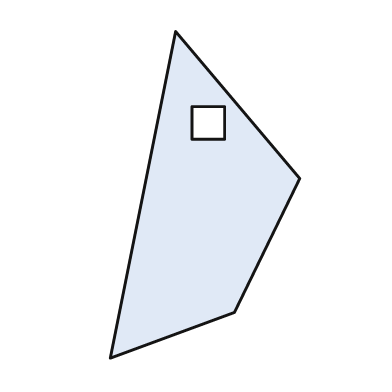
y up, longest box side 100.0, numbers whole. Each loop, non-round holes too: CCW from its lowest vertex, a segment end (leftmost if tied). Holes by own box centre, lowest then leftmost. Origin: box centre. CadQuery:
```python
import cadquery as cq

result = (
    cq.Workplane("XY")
    .moveTo(-29.0, -50.0)
    .lineTo(9.0, -36.0)
    .lineTo(29.0, 5.0)
    .lineTo(-9.0, 50.0)
    .close()
    .moveTo(-4.0, 17.0)
    .lineTo(6.0, 17.0)
    .lineTo(6.0, 27.0)
    .lineTo(-4.0, 27.0)
    .close()
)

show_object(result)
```